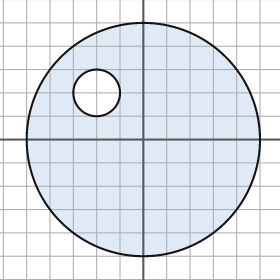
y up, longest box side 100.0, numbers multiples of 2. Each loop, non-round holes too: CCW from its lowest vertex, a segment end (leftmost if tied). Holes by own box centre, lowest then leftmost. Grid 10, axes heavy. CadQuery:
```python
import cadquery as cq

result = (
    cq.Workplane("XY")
    .moveTo(0.0, 0.0)
    .circle(50.0)
    .moveTo(-20.0, 20.0)
    .circle(10.0)
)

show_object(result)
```